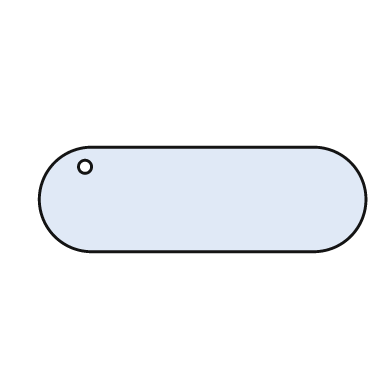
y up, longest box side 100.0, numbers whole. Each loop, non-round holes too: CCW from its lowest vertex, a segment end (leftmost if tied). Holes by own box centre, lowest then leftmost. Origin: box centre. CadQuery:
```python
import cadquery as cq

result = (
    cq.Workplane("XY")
    .moveTo(-34.0, -16.0)
    .lineTo(34.0, -16.0)
    .threePointArc((50.0, 0.0), (34.0, 16.0))
    .lineTo(-34.0, 16.0)
    .threePointArc((-50.0, 0.0), (-34.0, -16.0))
    .close()
    .moveTo(-36.0, 10.0)
    .circle(2.0)
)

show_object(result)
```